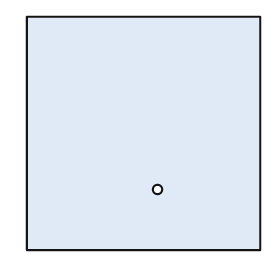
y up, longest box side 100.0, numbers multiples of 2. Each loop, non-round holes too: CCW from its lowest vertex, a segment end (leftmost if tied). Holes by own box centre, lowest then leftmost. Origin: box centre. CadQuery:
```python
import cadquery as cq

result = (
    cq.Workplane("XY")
    .moveTo(-50.0, -50.0)
    .lineTo(50.0, -50.0)
    .lineTo(50.0, 50.0)
    .lineTo(-50.0, 50.0)
    .close()
    .moveTo(6.0, -24.0)
    .circle(2.0)
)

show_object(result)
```